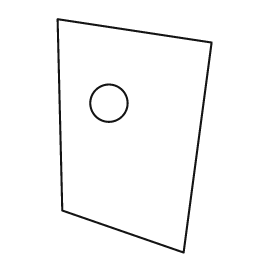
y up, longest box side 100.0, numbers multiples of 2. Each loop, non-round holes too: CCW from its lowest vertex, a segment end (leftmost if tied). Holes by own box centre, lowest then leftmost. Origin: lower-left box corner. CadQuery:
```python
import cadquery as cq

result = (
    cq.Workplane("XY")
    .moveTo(54.0, 0.0)
    .lineTo(66.0, 90.0)
    .lineTo(0.0, 100.0)
    .lineTo(2.0, 18.0)
    .close()
    .moveTo(22.0, 64.0)
    .circle(8.0)
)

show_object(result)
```